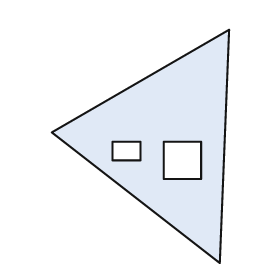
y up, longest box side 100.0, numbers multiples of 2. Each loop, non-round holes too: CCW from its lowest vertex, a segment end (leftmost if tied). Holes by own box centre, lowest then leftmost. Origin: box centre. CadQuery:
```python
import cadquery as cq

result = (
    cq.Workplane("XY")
    .moveTo(34.0, -50.0)
    .lineTo(38.0, 50.0)
    .lineTo(-38.0, 6.0)
    .close()
    .moveTo(10.0, -14.0)
    .lineTo(26.0, -14.0)
    .lineTo(26.0, 2.0)
    .lineTo(10.0, 2.0)
    .close()
    .moveTo(-12.0, -6.0)
    .lineTo(0.0, -6.0)
    .lineTo(0.0, 2.0)
    .lineTo(-12.0, 2.0)
    .close()
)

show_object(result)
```